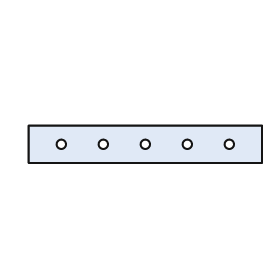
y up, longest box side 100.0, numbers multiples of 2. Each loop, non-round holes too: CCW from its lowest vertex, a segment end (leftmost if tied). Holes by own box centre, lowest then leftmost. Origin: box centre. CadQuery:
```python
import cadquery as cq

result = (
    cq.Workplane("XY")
    .moveTo(-50.0, -8.0)
    .lineTo(50.0, -8.0)
    .lineTo(50.0, 8.0)
    .lineTo(-50.0, 8.0)
    .close()
    .moveTo(-36.0, 0.0)
    .circle(2.0)
    .moveTo(-18.0, 0.0)
    .circle(2.0)
    .moveTo(0.0, 0.0)
    .circle(2.0)
    .moveTo(18.0, 0.0)
    .circle(2.0)
    .moveTo(36.0, 0.0)
    .circle(2.0)
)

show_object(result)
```